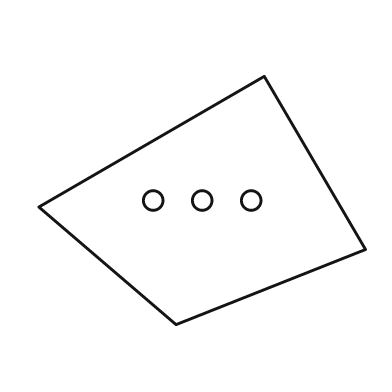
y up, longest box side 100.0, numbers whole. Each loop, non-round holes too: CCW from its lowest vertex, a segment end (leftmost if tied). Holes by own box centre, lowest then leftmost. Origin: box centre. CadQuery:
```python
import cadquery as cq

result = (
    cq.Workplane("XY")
    .moveTo(-8.0, -38.0)
    .lineTo(50.0, -15.0)
    .lineTo(19.0, 38.0)
    .lineTo(-50.0, -2.0)
    .close()
    .moveTo(-15.0, 0.0)
    .circle(3.0)
    .moveTo(0.0, 0.0)
    .circle(3.0)
    .moveTo(15.0, 0.0)
    .circle(3.0)
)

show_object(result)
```